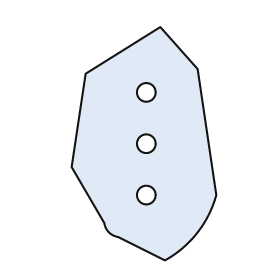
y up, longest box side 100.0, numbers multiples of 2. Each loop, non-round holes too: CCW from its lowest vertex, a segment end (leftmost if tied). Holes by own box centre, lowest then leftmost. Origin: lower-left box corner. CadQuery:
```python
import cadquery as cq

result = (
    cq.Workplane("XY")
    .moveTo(40.0, 0.0)
    .threePointArc((54.0, 12.0), (62.0, 28.0))
    .lineTo(54.0, 82.0)
    .lineTo(38.0, 100.0)
    .lineTo(6.0, 80.0)
    .lineTo(0.0, 40.0)
    .lineTo(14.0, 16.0)
    .threePointArc((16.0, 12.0), (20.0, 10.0))
    .close()
    .moveTo(32.0, 28.0)
    .circle(4.0)
    .moveTo(32.0, 50.0)
    .circle(4.0)
    .moveTo(32.0, 72.0)
    .circle(4.0)
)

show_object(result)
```